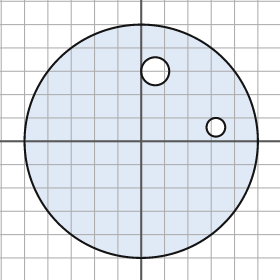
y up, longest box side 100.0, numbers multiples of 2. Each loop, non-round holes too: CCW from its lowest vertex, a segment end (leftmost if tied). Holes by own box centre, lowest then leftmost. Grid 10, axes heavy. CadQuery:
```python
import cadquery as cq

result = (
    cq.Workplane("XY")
    .moveTo(0.0, 0.0)
    .circle(50.0)
    .moveTo(32.0, 6.0)
    .circle(4.0)
    .moveTo(6.0, 30.0)
    .circle(6.0)
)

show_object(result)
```